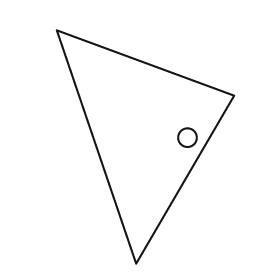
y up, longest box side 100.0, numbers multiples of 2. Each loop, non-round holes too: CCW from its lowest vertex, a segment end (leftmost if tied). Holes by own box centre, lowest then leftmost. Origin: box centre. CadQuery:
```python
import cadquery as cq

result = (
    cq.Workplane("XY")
    .moveTo(-4.0, -50.0)
    .lineTo(38.0, 22.0)
    .lineTo(-38.0, 50.0)
    .close()
    .moveTo(18.0, 4.0)
    .circle(4.0)
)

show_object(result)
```